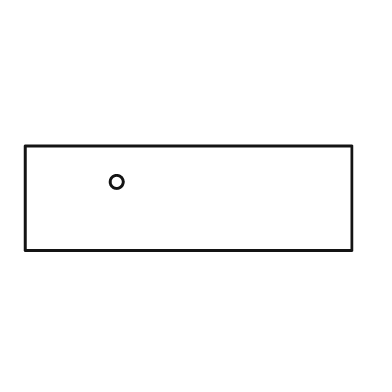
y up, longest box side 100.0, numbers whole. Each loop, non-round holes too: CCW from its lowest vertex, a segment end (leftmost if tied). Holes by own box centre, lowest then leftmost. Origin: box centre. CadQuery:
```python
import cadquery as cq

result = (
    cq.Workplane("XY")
    .moveTo(-50.0, -16.0)
    .lineTo(50.0, -16.0)
    .lineTo(50.0, 16.0)
    .lineTo(-50.0, 16.0)
    .close()
    .moveTo(-22.0, 5.0)
    .circle(2.0)
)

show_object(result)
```